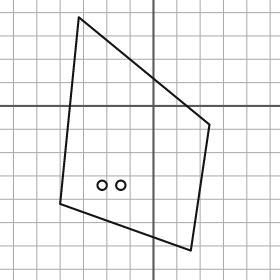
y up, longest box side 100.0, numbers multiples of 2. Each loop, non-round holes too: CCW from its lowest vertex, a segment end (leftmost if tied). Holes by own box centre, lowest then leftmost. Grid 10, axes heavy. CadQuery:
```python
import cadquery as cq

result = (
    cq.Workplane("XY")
    .moveTo(16.0, -62.0)
    .lineTo(24.0, -8.0)
    .lineTo(-32.0, 38.0)
    .lineTo(-40.0, -42.0)
    .close()
    .moveTo(-22.0, -34.0)
    .circle(2.0)
    .moveTo(-14.0, -34.0)
    .circle(2.0)
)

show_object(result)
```